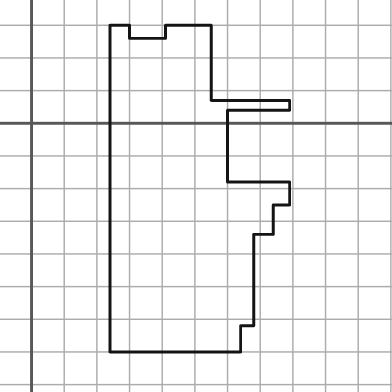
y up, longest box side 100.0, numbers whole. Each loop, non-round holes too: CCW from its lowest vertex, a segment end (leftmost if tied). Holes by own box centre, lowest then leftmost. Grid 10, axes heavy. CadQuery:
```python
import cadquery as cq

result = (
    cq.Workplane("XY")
    .moveTo(24.0, -70.0)
    .lineTo(64.0, -70.0)
    .lineTo(64.0, -62.0)
    .lineTo(68.0, -62.0)
    .lineTo(68.0, -34.0)
    .lineTo(74.0, -34.0)
    .lineTo(74.0, -25.0)
    .lineTo(79.0, -25.0)
    .lineTo(79.0, -18.0)
    .lineTo(60.0, -18.0)
    .lineTo(60.0, 4.0)
    .lineTo(79.0, 4.0)
    .lineTo(79.0, 7.0)
    .lineTo(55.0, 7.0)
    .lineTo(55.0, 30.0)
    .lineTo(41.0, 30.0)
    .lineTo(41.0, 26.0)
    .lineTo(30.0, 26.0)
    .lineTo(30.0, 30.0)
    .lineTo(24.0, 30.0)
    .close()
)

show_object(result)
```